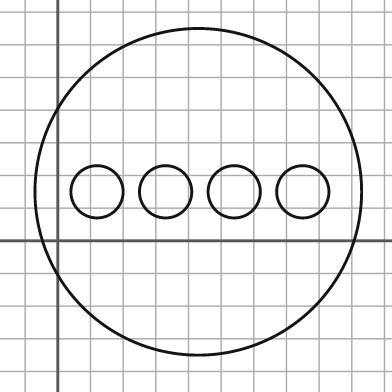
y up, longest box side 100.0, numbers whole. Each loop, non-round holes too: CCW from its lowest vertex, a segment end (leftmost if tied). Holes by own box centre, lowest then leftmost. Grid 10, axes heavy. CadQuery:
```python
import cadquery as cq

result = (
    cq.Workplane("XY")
    .moveTo(43.0, 15.0)
    .circle(50.0)
    .moveTo(12.0, 15.0)
    .circle(8.0)
    .moveTo(33.0, 15.0)
    .circle(8.0)
    .moveTo(54.0, 15.0)
    .circle(8.0)
    .moveTo(75.0, 15.0)
    .circle(8.0)
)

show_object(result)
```